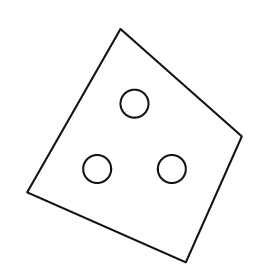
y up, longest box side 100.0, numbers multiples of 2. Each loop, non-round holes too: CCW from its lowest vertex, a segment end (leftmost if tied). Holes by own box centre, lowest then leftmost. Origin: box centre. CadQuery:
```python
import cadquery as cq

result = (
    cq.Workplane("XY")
    .moveTo(22.0, -50.0)
    .lineTo(46.0, 4.0)
    .lineTo(-6.0, 50.0)
    .lineTo(-46.0, -20.0)
    .close()
    .moveTo(-16.0, -10.0)
    .circle(6.0)
    .moveTo(16.0, -10.0)
    .circle(6.0)
    .moveTo(0.0, 18.0)
    .circle(6.0)
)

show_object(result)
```